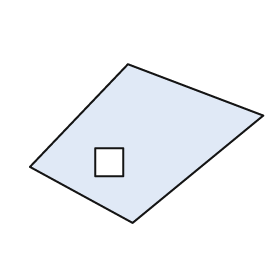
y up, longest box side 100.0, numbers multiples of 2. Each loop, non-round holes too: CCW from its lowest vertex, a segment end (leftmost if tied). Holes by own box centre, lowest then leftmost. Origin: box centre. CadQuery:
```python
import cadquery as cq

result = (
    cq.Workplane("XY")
    .moveTo(-6.0, -34.0)
    .lineTo(50.0, 12.0)
    .lineTo(-8.0, 34.0)
    .lineTo(-50.0, -10.0)
    .close()
    .moveTo(-22.0, -14.0)
    .lineTo(-10.0, -14.0)
    .lineTo(-10.0, -2.0)
    .lineTo(-22.0, -2.0)
    .close()
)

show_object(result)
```